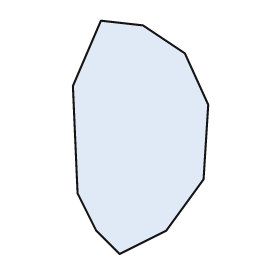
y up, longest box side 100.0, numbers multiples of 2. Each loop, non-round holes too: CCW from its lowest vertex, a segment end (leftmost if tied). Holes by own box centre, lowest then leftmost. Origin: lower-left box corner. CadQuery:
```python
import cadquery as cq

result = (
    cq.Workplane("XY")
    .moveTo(20.0, 0.0)
    .lineTo(40.0, 10.0)
    .lineTo(56.0, 32.0)
    .lineTo(58.0, 64.0)
    .lineTo(48.0, 86.0)
    .lineTo(30.0, 98.0)
    .lineTo(12.0, 100.0)
    .lineTo(0.0, 72.0)
    .lineTo(2.0, 26.0)
    .lineTo(10.0, 10.0)
    .close()
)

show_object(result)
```